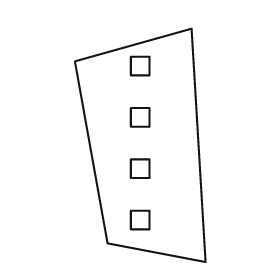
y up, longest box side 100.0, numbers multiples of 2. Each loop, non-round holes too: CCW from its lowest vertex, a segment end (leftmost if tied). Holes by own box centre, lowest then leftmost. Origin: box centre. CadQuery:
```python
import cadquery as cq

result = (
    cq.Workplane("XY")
    .moveTo(28.0, -50.0)
    .lineTo(22.0, 50.0)
    .lineTo(-28.0, 36.0)
    .lineTo(-14.0, -42.0)
    .close()
    .moveTo(-4.0, -36.0)
    .lineTo(4.0, -36.0)
    .lineTo(4.0, -28.0)
    .lineTo(-4.0, -28.0)
    .close()
    .moveTo(-4.0, -14.0)
    .lineTo(4.0, -14.0)
    .lineTo(4.0, -6.0)
    .lineTo(-4.0, -6.0)
    .close()
    .moveTo(-4.0, 8.0)
    .lineTo(4.0, 8.0)
    .lineTo(4.0, 16.0)
    .lineTo(-4.0, 16.0)
    .close()
    .moveTo(-4.0, 30.0)
    .lineTo(4.0, 30.0)
    .lineTo(4.0, 38.0)
    .lineTo(-4.0, 38.0)
    .close()
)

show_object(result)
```